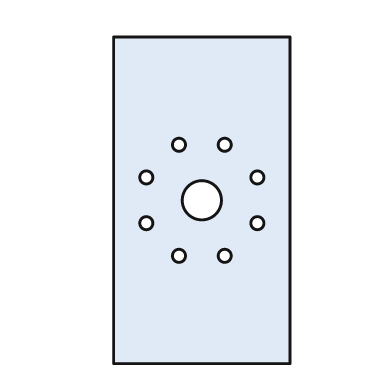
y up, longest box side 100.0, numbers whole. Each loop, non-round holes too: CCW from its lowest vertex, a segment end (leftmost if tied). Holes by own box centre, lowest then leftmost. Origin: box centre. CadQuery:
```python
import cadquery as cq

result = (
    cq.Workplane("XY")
    .moveTo(-27.0, -50.0)
    .lineTo(27.0, -50.0)
    .lineTo(27.0, 50.0)
    .lineTo(-27.0, 50.0)
    .close()
    .moveTo(-7.0, -17.0)
    .circle(2.0)
    .moveTo(7.0, -17.0)
    .circle(2.0)
    .moveTo(-17.0, -7.0)
    .circle(2.0)
    .moveTo(17.0, -7.0)
    .circle(2.0)
    .moveTo(0.0, 0.0)
    .circle(6.0)
    .moveTo(-17.0, 7.0)
    .circle(2.0)
    .moveTo(17.0, 7.0)
    .circle(2.0)
    .moveTo(-7.0, 17.0)
    .circle(2.0)
    .moveTo(7.0, 17.0)
    .circle(2.0)
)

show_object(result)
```